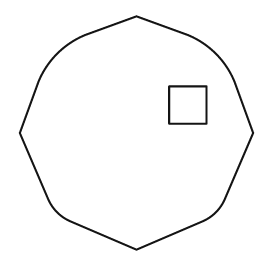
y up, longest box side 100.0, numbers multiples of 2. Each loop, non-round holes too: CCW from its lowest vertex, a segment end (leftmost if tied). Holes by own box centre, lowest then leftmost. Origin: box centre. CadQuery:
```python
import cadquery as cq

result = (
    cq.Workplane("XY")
    .moveTo(0.0, -50.0)
    .lineTo(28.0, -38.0)
    .threePointArc((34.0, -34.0), (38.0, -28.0))
    .lineTo(50.0, 0.0)
    .lineTo(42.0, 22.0)
    .threePointArc((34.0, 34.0), (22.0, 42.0))
    .lineTo(0.0, 50.0)
    .lineTo(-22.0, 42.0)
    .threePointArc((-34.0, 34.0), (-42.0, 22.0))
    .lineTo(-50.0, 0.0)
    .lineTo(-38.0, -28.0)
    .threePointArc((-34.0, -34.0), (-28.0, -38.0))
    .close()
    .moveTo(14.0, 4.0)
    .lineTo(30.0, 4.0)
    .lineTo(30.0, 20.0)
    .lineTo(14.0, 20.0)
    .close()
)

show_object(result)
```